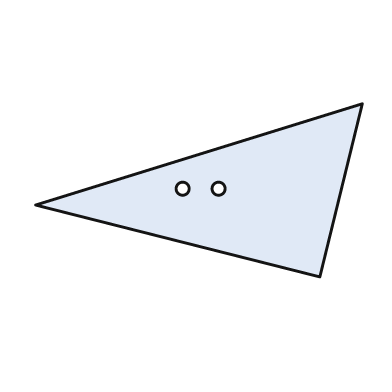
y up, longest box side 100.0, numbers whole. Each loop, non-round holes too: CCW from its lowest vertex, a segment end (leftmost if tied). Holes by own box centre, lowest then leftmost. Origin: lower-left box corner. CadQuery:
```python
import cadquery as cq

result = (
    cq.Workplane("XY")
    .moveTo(87.0, 0.0)
    .lineTo(100.0, 53.0)
    .lineTo(0.0, 22.0)
    .close()
    .moveTo(45.0, 27.0)
    .circle(2.0)
    .moveTo(56.0, 27.0)
    .circle(2.0)
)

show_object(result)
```